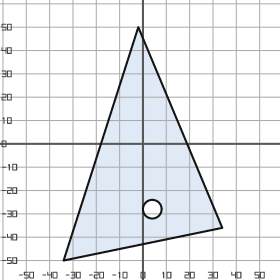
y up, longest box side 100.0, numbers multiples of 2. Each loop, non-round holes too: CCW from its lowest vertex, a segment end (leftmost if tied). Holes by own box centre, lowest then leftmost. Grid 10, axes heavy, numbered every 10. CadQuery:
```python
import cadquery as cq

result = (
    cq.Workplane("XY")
    .moveTo(-34.0, -50.0)
    .lineTo(34.0, -36.0)
    .lineTo(-2.0, 50.0)
    .close()
    .moveTo(4.0, -28.0)
    .circle(4.0)
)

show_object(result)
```